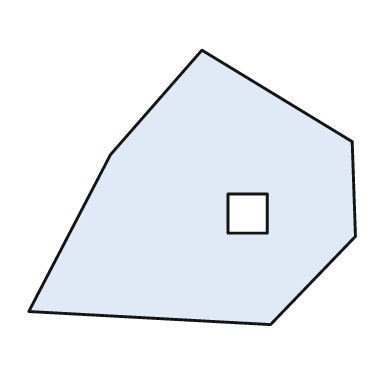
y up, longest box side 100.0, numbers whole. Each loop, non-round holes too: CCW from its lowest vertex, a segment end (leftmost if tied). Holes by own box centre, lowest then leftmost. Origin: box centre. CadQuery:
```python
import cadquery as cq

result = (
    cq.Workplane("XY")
    .moveTo(24.0, -42.0)
    .lineTo(50.0, -15.0)
    .lineTo(49.0, 14.0)
    .lineTo(3.0, 42.0)
    .lineTo(-25.0, 10.0)
    .lineTo(-50.0, -38.0)
    .close()
    .moveTo(11.0, -14.0)
    .lineTo(23.0, -14.0)
    .lineTo(23.0, -2.0)
    .lineTo(11.0, -2.0)
    .close()
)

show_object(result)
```